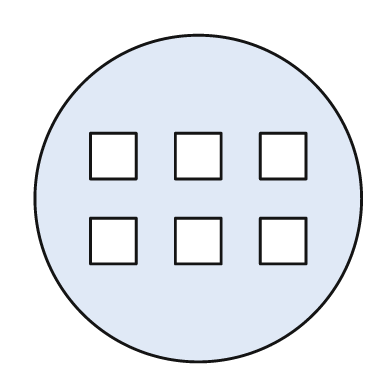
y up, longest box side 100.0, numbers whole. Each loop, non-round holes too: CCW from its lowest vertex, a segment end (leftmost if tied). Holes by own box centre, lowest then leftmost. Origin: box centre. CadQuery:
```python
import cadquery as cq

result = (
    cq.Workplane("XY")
    .moveTo(0.0, 0.0)
    .circle(50.0)
    .moveTo(-33.0, -20.0)
    .lineTo(-19.0, -20.0)
    .lineTo(-19.0, -6.0)
    .lineTo(-33.0, -6.0)
    .close()
    .moveTo(-7.0, -20.0)
    .lineTo(7.0, -20.0)
    .lineTo(7.0, -6.0)
    .lineTo(-7.0, -6.0)
    .close()
    .moveTo(19.0, -20.0)
    .lineTo(33.0, -20.0)
    .lineTo(33.0, -6.0)
    .lineTo(19.0, -6.0)
    .close()
    .moveTo(-33.0, 6.0)
    .lineTo(-19.0, 6.0)
    .lineTo(-19.0, 20.0)
    .lineTo(-33.0, 20.0)
    .close()
    .moveTo(-7.0, 6.0)
    .lineTo(7.0, 6.0)
    .lineTo(7.0, 20.0)
    .lineTo(-7.0, 20.0)
    .close()
    .moveTo(19.0, 6.0)
    .lineTo(33.0, 6.0)
    .lineTo(33.0, 20.0)
    .lineTo(19.0, 20.0)
    .close()
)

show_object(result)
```